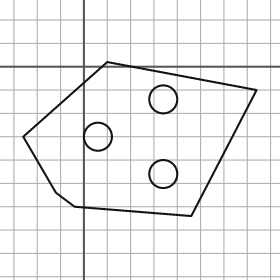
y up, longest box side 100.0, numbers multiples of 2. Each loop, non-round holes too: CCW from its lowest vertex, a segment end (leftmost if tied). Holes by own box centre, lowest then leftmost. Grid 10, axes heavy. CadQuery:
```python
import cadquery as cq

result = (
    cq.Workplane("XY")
    .moveTo(46.0, -64.0)
    .lineTo(74.0, -10.0)
    .lineTo(10.0, 2.0)
    .lineTo(-26.0, -30.0)
    .lineTo(-12.0, -54.0)
    .lineTo(-4.0, -60.0)
    .close()
    .moveTo(34.0, -46.0)
    .circle(6.0)
    .moveTo(6.0, -30.0)
    .circle(6.0)
    .moveTo(34.0, -14.0)
    .circle(6.0)
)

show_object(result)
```